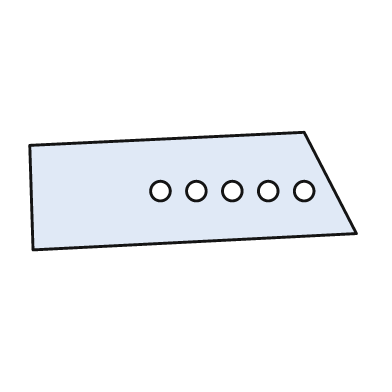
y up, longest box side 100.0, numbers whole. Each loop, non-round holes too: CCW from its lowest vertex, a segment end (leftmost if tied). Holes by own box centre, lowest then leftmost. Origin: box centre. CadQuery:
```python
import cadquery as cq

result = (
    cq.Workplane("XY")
    .moveTo(-49.0, -18.0)
    .lineTo(50.0, -13.0)
    .lineTo(34.0, 18.0)
    .lineTo(-50.0, 14.0)
    .close()
    .moveTo(-10.0, 0.0)
    .circle(3.0)
    .moveTo(1.0, 0.0)
    .circle(3.0)
    .moveTo(12.0, 0.0)
    .circle(3.0)
    .moveTo(23.0, 0.0)
    .circle(3.0)
    .moveTo(34.0, 0.0)
    .circle(3.0)
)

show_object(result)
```